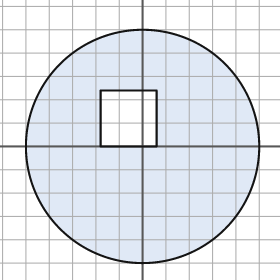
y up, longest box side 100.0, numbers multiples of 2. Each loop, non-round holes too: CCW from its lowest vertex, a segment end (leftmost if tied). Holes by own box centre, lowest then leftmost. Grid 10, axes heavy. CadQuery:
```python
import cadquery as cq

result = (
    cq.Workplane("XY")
    .moveTo(0.0, 0.0)
    .circle(50.0)
    .moveTo(-18.0, 0.0)
    .lineTo(6.0, 0.0)
    .lineTo(6.0, 24.0)
    .lineTo(-18.0, 24.0)
    .close()
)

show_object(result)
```